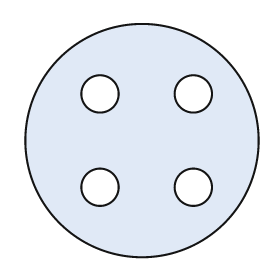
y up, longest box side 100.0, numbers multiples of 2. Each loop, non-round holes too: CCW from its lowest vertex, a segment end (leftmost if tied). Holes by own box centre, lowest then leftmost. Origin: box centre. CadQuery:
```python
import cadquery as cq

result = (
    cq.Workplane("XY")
    .moveTo(0.0, 0.0)
    .circle(50.0)
    .moveTo(-18.0, -20.0)
    .circle(8.0)
    .moveTo(22.0, -20.0)
    .circle(8.0)
    .moveTo(-18.0, 20.0)
    .circle(8.0)
    .moveTo(22.0, 20.0)
    .circle(8.0)
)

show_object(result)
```